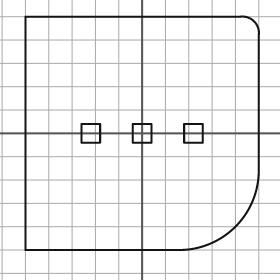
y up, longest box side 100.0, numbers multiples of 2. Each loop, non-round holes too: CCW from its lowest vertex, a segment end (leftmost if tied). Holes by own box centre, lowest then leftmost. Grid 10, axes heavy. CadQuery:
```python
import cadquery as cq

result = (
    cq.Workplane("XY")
    .moveTo(-50.0, -50.0)
    .lineTo(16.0, -50.0)
    .threePointArc((40.0, -40.0), (50.0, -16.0))
    .lineTo(50.0, 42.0)
    .threePointArc((48.0, 48.0), (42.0, 50.0))
    .lineTo(-50.0, 50.0)
    .close()
    .moveTo(-26.0, -4.0)
    .lineTo(-18.0, -4.0)
    .lineTo(-18.0, 4.0)
    .lineTo(-26.0, 4.0)
    .close()
    .moveTo(-4.0, -4.0)
    .lineTo(4.0, -4.0)
    .lineTo(4.0, 4.0)
    .lineTo(-4.0, 4.0)
    .close()
    .moveTo(18.0, -4.0)
    .lineTo(26.0, -4.0)
    .lineTo(26.0, 4.0)
    .lineTo(18.0, 4.0)
    .close()
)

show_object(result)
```